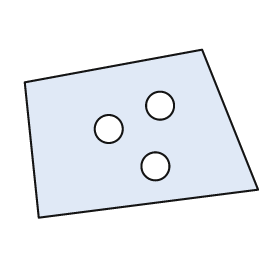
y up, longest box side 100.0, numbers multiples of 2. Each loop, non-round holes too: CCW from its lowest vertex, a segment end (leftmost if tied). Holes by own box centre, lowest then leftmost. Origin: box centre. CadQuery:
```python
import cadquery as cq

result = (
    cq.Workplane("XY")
    .moveTo(-44.0, -36.0)
    .lineTo(50.0, -24.0)
    .lineTo(26.0, 36.0)
    .lineTo(-50.0, 22.0)
    .close()
    .moveTo(6.0, -14.0)
    .circle(6.0)
    .moveTo(-14.0, 2.0)
    .circle(6.0)
    .moveTo(8.0, 12.0)
    .circle(6.0)
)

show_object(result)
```